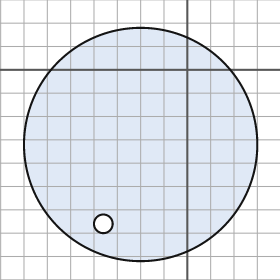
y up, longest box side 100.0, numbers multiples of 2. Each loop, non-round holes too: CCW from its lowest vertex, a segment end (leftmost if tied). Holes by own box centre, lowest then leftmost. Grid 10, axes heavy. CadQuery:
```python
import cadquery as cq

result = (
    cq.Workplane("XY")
    .moveTo(-20.0, -32.0)
    .circle(50.0)
    .moveTo(-36.0, -66.0)
    .circle(4.0)
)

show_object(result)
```